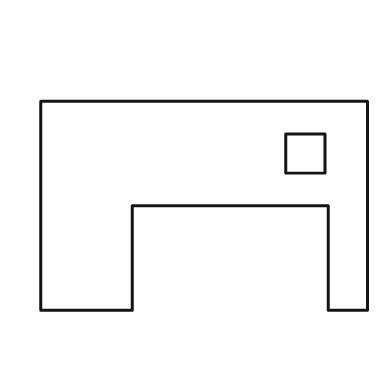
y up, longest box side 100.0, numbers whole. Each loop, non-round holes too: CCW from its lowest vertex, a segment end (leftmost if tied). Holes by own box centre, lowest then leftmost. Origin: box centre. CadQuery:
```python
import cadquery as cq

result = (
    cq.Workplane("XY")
    .moveTo(-50.0, -32.0)
    .lineTo(-22.0, -32.0)
    .lineTo(-22.0, 0.0)
    .lineTo(38.0, 0.0)
    .lineTo(38.0, -32.0)
    .lineTo(50.0, -32.0)
    .lineTo(50.0, 32.0)
    .lineTo(-50.0, 32.0)
    .close()
    .moveTo(25.0, 10.0)
    .lineTo(37.0, 10.0)
    .lineTo(37.0, 22.0)
    .lineTo(25.0, 22.0)
    .close()
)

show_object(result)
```